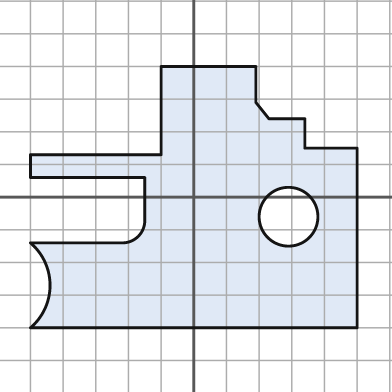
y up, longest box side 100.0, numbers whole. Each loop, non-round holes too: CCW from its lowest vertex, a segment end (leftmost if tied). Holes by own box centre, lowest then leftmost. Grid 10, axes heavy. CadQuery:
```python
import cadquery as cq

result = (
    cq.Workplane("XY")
    .moveTo(-50.0, -40.0)
    .lineTo(50.0, -40.0)
    .lineTo(50.0, 15.0)
    .lineTo(34.0, 15.0)
    .lineTo(34.0, 24.0)
    .lineTo(23.0, 24.0)
    .lineTo(19.0, 29.0)
    .lineTo(19.0, 40.0)
    .lineTo(-10.0, 40.0)
    .lineTo(-10.0, 13.0)
    .lineTo(-50.0, 13.0)
    .lineTo(-50.0, 6.0)
    .lineTo(-15.0, 6.0)
    .lineTo(-15.0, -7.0)
    .threePointArc((-17.0, -12.0), (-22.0, -14.0))
    .lineTo(-50.0, -14.0)
    .threePointArc((-44.0, -27.0), (-50.0, -40.0))
    .close()
    .moveTo(29.0, -6.0)
    .circle(9.0)
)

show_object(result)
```